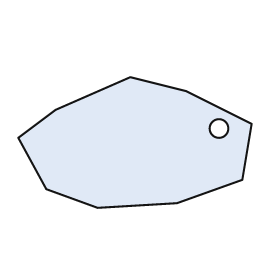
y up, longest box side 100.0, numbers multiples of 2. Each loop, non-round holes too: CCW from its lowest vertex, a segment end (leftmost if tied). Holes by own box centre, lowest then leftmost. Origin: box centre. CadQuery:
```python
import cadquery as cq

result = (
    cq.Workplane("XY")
    .moveTo(-16.0, -28.0)
    .lineTo(18.0, -26.0)
    .lineTo(46.0, -16.0)
    .lineTo(50.0, 8.0)
    .lineTo(22.0, 22.0)
    .lineTo(-2.0, 28.0)
    .lineTo(-34.0, 14.0)
    .lineTo(-50.0, 2.0)
    .lineTo(-38.0, -20.0)
    .close()
    .moveTo(36.0, 6.0)
    .circle(4.0)
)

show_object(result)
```